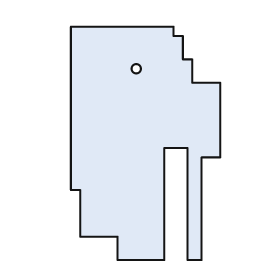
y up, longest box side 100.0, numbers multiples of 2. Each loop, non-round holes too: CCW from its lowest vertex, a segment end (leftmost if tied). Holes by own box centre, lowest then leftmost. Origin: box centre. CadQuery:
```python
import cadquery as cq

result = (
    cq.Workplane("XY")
    .moveTo(-12.0, -50.0)
    .lineTo(8.0, -50.0)
    .lineTo(8.0, -2.0)
    .lineTo(18.0, -2.0)
    .lineTo(18.0, -50.0)
    .lineTo(24.0, -50.0)
    .lineTo(24.0, -6.0)
    .lineTo(32.0, -6.0)
    .lineTo(32.0, 26.0)
    .lineTo(20.0, 26.0)
    .lineTo(20.0, 36.0)
    .lineTo(16.0, 36.0)
    .lineTo(16.0, 46.0)
    .lineTo(12.0, 46.0)
    .lineTo(12.0, 50.0)
    .lineTo(-32.0, 50.0)
    .lineTo(-32.0, -20.0)
    .lineTo(-28.0, -20.0)
    .lineTo(-28.0, -40.0)
    .lineTo(-12.0, -40.0)
    .close()
    .moveTo(-4.0, 32.0)
    .circle(2.0)
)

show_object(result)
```